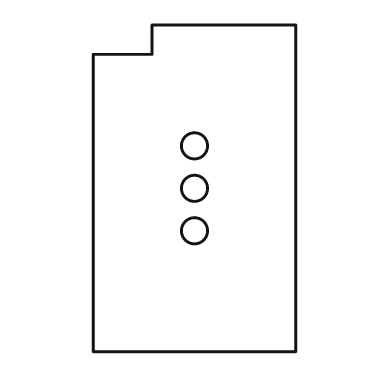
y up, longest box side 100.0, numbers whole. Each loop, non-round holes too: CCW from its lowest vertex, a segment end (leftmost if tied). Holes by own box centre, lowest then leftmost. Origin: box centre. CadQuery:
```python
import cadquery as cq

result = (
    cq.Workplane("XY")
    .moveTo(-31.0, -50.0)
    .lineTo(31.0, -50.0)
    .lineTo(31.0, 50.0)
    .lineTo(-13.0, 50.0)
    .lineTo(-13.0, 41.0)
    .lineTo(-31.0, 41.0)
    .close()
    .moveTo(0.0, -13.0)
    .circle(4.0)
    .moveTo(0.0, 0.0)
    .circle(4.0)
    .moveTo(0.0, 13.0)
    .circle(4.0)
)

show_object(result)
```